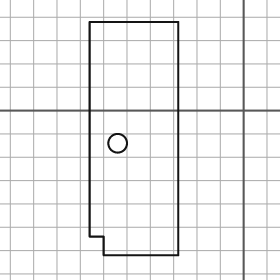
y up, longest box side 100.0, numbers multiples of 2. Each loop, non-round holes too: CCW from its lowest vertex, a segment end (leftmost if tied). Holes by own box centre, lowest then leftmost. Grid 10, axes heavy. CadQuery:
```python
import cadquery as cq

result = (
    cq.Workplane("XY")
    .moveTo(-60.0, -62.0)
    .lineTo(-28.0, -62.0)
    .lineTo(-28.0, 38.0)
    .lineTo(-66.0, 38.0)
    .lineTo(-66.0, -54.0)
    .lineTo(-60.0, -54.0)
    .close()
    .moveTo(-54.0, -14.0)
    .circle(4.0)
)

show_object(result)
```